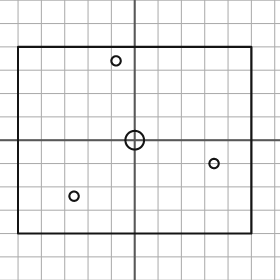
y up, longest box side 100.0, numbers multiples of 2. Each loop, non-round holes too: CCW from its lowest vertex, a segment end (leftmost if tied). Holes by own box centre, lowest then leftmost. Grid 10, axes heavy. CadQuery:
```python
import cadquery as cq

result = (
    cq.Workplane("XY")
    .moveTo(-50.0, -40.0)
    .lineTo(50.0, -40.0)
    .lineTo(50.0, 40.0)
    .lineTo(-50.0, 40.0)
    .close()
    .moveTo(-26.0, -24.0)
    .circle(2.0)
    .moveTo(34.0, -10.0)
    .circle(2.0)
    .moveTo(0.0, 0.0)
    .circle(4.0)
    .moveTo(-8.0, 34.0)
    .circle(2.0)
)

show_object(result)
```